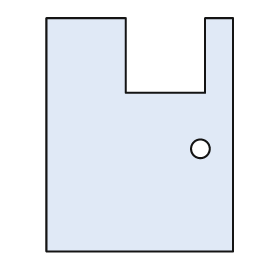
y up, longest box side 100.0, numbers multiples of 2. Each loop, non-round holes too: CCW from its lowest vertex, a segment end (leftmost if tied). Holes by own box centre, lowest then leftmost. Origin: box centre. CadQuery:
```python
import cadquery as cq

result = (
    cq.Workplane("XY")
    .moveTo(-40.0, -50.0)
    .lineTo(40.0, -50.0)
    .lineTo(40.0, 50.0)
    .lineTo(28.0, 50.0)
    .lineTo(28.0, 18.0)
    .lineTo(-6.0, 18.0)
    .lineTo(-6.0, 50.0)
    .lineTo(-40.0, 50.0)
    .close()
    .moveTo(26.0, -6.0)
    .circle(4.0)
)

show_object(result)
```